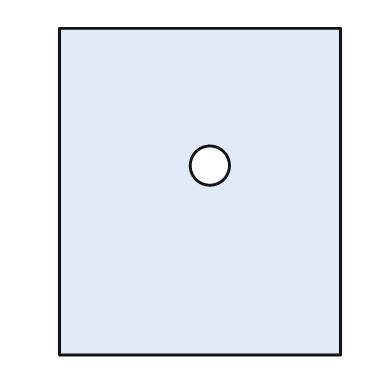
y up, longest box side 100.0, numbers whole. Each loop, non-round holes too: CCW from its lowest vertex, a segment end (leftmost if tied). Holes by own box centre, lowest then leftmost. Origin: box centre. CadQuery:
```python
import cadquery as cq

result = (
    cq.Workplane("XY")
    .moveTo(-43.0, -50.0)
    .lineTo(43.0, -50.0)
    .lineTo(43.0, 50.0)
    .lineTo(-43.0, 50.0)
    .close()
    .moveTo(3.0, 8.0)
    .circle(6.0)
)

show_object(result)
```